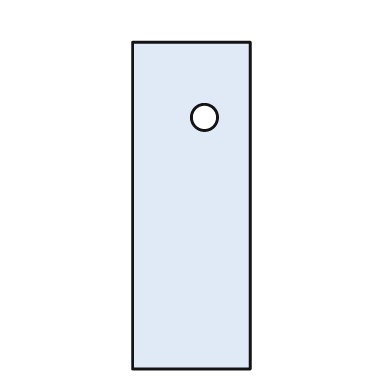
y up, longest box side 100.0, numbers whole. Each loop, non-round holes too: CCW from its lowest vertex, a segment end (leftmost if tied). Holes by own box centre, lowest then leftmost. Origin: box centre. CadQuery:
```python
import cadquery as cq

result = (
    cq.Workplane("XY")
    .moveTo(-18.0, -50.0)
    .lineTo(18.0, -50.0)
    .lineTo(18.0, 50.0)
    .lineTo(-18.0, 50.0)
    .close()
    .moveTo(4.0, 27.0)
    .circle(4.0)
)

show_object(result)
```